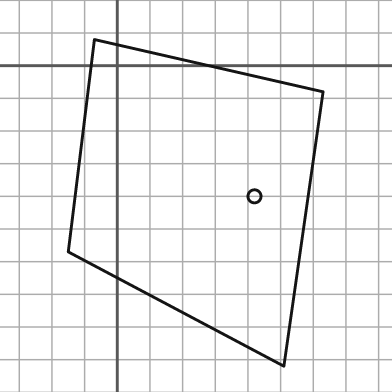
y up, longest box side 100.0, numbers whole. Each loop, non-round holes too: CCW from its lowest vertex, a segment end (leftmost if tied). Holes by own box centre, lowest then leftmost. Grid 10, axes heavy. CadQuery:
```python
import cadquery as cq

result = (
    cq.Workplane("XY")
    .moveTo(51.0, -92.0)
    .lineTo(63.0, -8.0)
    .lineTo(-7.0, 8.0)
    .lineTo(-15.0, -57.0)
    .close()
    .moveTo(42.0, -40.0)
    .circle(2.0)
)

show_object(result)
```